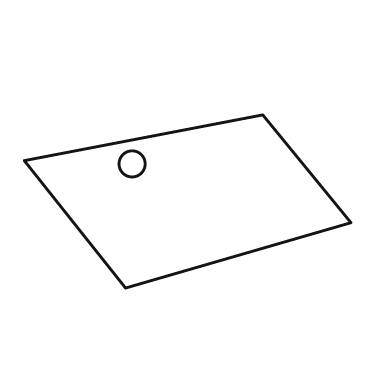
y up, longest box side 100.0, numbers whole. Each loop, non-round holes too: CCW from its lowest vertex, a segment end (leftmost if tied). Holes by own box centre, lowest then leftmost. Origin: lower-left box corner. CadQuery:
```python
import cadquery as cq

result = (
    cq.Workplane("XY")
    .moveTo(31.0, 0.0)
    .lineTo(100.0, 20.0)
    .lineTo(73.0, 53.0)
    .lineTo(0.0, 39.0)
    .close()
    .moveTo(33.0, 38.0)
    .circle(4.0)
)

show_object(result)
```